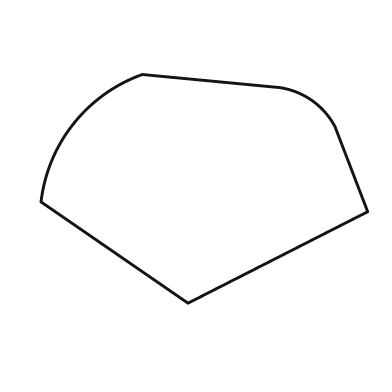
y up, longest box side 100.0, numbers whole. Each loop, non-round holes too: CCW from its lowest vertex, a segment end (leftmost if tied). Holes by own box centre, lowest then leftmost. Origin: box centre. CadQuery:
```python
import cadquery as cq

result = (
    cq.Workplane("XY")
    .moveTo(-5.0, -35.0)
    .lineTo(50.0, -7.0)
    .lineTo(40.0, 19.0)
    .threePointArc((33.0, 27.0), (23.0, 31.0))
    .lineTo(-19.0, 35.0)
    .threePointArc((-40.0, 20.0), (-50.0, -4.0))
    .close()
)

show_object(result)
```